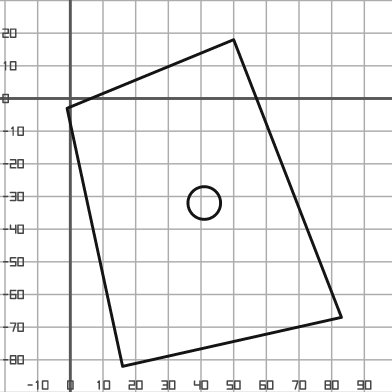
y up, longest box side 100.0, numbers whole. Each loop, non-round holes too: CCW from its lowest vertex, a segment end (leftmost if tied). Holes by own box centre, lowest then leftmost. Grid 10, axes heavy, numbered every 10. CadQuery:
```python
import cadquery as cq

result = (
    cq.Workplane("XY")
    .moveTo(16.0, -82.0)
    .lineTo(83.0, -67.0)
    .lineTo(50.0, 18.0)
    .lineTo(-1.0, -3.0)
    .close()
    .moveTo(41.0, -32.0)
    .circle(5.0)
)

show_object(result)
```